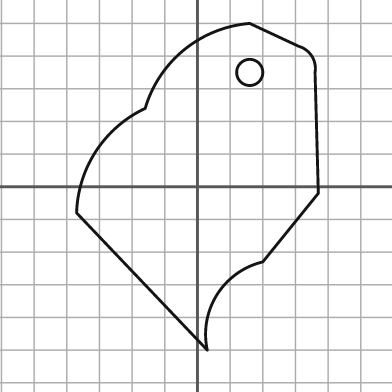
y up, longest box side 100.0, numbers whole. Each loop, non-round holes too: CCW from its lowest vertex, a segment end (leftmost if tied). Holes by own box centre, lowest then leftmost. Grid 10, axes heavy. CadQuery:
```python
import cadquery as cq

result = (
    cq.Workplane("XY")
    .moveTo(3.0, -50.0)
    .threePointArc((6.0, -33.0), (20.0, -23.0))
    .lineTo(37.0, -2.0)
    .lineTo(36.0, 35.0)
    .threePointArc((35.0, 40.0), (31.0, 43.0))
    .lineTo(16.0, 50.0)
    .threePointArc((-4.0, 42.0), (-16.0, 24.0))
    .threePointArc((-31.0, 11.0), (-37.0, -8.0))
    .close()
    .moveTo(16.0, 35.0)
    .circle(4.0)
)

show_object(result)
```